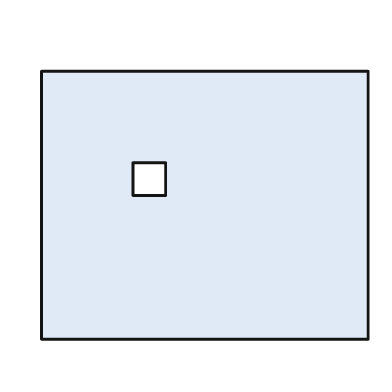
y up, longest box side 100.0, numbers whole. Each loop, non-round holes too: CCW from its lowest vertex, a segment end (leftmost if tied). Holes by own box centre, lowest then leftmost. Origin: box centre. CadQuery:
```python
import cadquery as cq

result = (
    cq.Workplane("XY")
    .moveTo(-50.0, -41.0)
    .lineTo(50.0, -41.0)
    .lineTo(50.0, 41.0)
    .lineTo(-50.0, 41.0)
    .close()
    .moveTo(-22.0, 3.0)
    .lineTo(-12.0, 3.0)
    .lineTo(-12.0, 13.0)
    .lineTo(-22.0, 13.0)
    .close()
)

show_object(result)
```